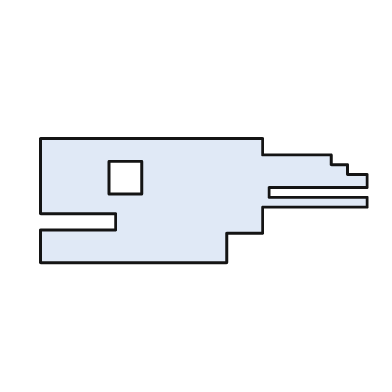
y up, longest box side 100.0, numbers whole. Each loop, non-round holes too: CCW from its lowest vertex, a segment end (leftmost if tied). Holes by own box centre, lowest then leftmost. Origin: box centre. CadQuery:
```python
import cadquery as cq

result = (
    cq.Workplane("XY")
    .moveTo(-50.0, -19.0)
    .lineTo(7.0, -19.0)
    .lineTo(7.0, -10.0)
    .lineTo(18.0, -10.0)
    .lineTo(18.0, -2.0)
    .lineTo(50.0, -2.0)
    .lineTo(50.0, 1.0)
    .lineTo(20.0, 1.0)
    .lineTo(20.0, 4.0)
    .lineTo(50.0, 4.0)
    .lineTo(50.0, 8.0)
    .lineTo(44.0, 8.0)
    .lineTo(44.0, 11.0)
    .lineTo(39.0, 11.0)
    .lineTo(39.0, 14.0)
    .lineTo(18.0, 14.0)
    .lineTo(18.0, 19.0)
    .lineTo(-50.0, 19.0)
    .lineTo(-50.0, -4.0)
    .lineTo(-27.0, -4.0)
    .lineTo(-27.0, -9.0)
    .lineTo(-50.0, -9.0)
    .close()
    .moveTo(-29.0, 2.0)
    .lineTo(-19.0, 2.0)
    .lineTo(-19.0, 12.0)
    .lineTo(-29.0, 12.0)
    .close()
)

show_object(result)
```